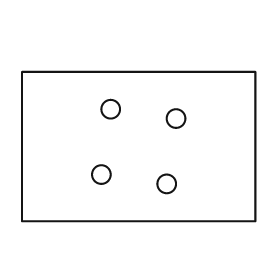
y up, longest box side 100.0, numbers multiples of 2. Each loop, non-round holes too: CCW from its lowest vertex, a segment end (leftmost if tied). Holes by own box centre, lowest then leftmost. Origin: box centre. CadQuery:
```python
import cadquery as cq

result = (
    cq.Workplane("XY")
    .moveTo(-50.0, -32.0)
    .lineTo(50.0, -32.0)
    .lineTo(50.0, 32.0)
    .lineTo(-50.0, 32.0)
    .close()
    .moveTo(12.0, -16.0)
    .circle(4.0)
    .moveTo(-16.0, -12.0)
    .circle(4.0)
    .moveTo(16.0, 12.0)
    .circle(4.0)
    .moveTo(-12.0, 16.0)
    .circle(4.0)
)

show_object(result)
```